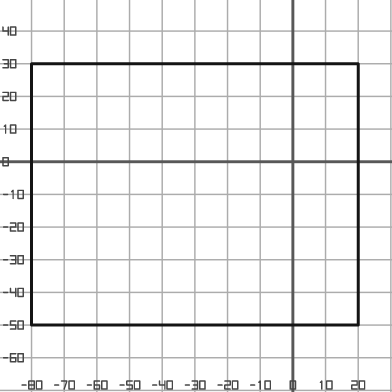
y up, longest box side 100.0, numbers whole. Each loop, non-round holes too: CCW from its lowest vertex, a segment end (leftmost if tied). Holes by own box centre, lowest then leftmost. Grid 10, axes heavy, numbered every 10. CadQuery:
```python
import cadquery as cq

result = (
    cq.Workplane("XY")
    .moveTo(-80.0, -50.0)
    .lineTo(20.0, -50.0)
    .lineTo(20.0, 30.0)
    .lineTo(-80.0, 30.0)
    .close()
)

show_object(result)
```